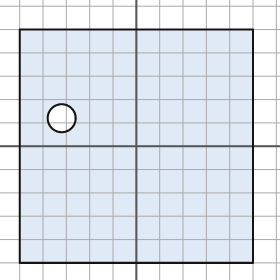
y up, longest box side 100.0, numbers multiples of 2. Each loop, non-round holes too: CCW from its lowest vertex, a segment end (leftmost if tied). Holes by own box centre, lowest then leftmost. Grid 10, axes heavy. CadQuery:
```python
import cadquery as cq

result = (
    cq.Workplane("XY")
    .moveTo(-50.0, -50.0)
    .lineTo(50.0, -50.0)
    .lineTo(50.0, 50.0)
    .lineTo(-50.0, 50.0)
    .close()
    .moveTo(-32.0, 12.0)
    .circle(6.0)
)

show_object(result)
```